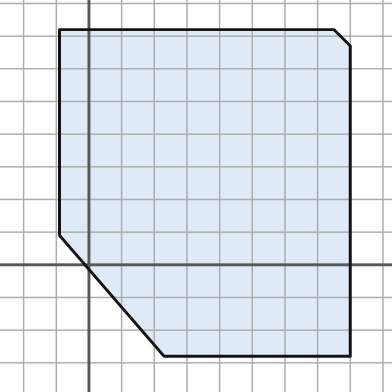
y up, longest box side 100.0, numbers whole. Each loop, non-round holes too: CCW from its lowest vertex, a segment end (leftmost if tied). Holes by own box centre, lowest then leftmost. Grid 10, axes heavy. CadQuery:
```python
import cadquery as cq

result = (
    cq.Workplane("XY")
    .moveTo(23.0, -28.0)
    .lineTo(80.0, -28.0)
    .lineTo(80.0, 67.0)
    .lineTo(75.0, 72.0)
    .lineTo(-9.0, 72.0)
    .lineTo(-9.0, 9.0)
    .close()
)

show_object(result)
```